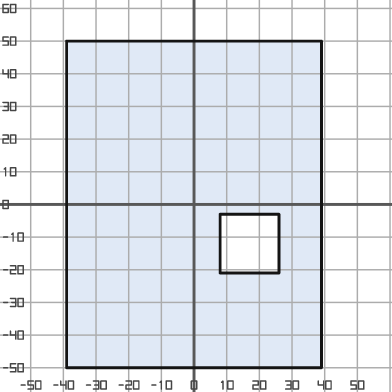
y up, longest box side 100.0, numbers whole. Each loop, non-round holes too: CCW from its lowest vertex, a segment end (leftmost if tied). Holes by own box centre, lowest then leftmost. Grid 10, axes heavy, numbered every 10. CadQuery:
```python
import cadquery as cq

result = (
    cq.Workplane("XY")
    .moveTo(-39.0, -50.0)
    .lineTo(39.0, -50.0)
    .lineTo(39.0, 50.0)
    .lineTo(-39.0, 50.0)
    .close()
    .moveTo(8.0, -21.0)
    .lineTo(26.0, -21.0)
    .lineTo(26.0, -3.0)
    .lineTo(8.0, -3.0)
    .close()
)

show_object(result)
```